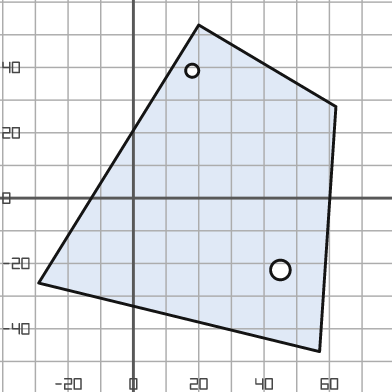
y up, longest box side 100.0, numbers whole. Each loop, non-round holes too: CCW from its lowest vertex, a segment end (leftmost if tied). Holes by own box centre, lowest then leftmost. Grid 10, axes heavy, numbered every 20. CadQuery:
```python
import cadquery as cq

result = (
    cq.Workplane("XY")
    .moveTo(57.0, -47.0)
    .lineTo(62.0, 28.0)
    .lineTo(20.0, 53.0)
    .lineTo(-29.0, -26.0)
    .close()
    .moveTo(45.0, -22.0)
    .circle(3.0)
    .moveTo(18.0, 39.0)
    .circle(2.0)
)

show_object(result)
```